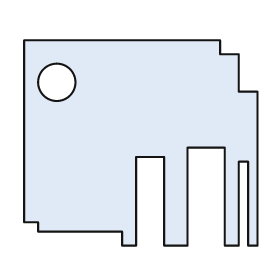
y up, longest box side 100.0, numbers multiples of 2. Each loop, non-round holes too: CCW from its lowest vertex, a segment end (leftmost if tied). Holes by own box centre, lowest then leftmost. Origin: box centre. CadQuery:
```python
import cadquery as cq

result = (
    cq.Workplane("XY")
    .moveTo(-8.0, -44.0)
    .lineTo(-2.0, -44.0)
    .lineTo(-2.0, -6.0)
    .lineTo(10.0, -6.0)
    .lineTo(10.0, -44.0)
    .lineTo(20.0, -44.0)
    .lineTo(20.0, -2.0)
    .lineTo(36.0, -2.0)
    .lineTo(36.0, -44.0)
    .lineTo(42.0, -44.0)
    .lineTo(42.0, -8.0)
    .lineTo(46.0, -8.0)
    .lineTo(46.0, -44.0)
    .lineTo(50.0, -44.0)
    .lineTo(50.0, 22.0)
    .lineTo(42.0, 22.0)
    .lineTo(42.0, 38.0)
    .lineTo(34.0, 38.0)
    .lineTo(34.0, 44.0)
    .lineTo(-50.0, 44.0)
    .lineTo(-50.0, -34.0)
    .lineTo(-44.0, -34.0)
    .lineTo(-44.0, -38.0)
    .lineTo(-8.0, -38.0)
    .close()
    .moveTo(-36.0, 26.0)
    .circle(8.0)
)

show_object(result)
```